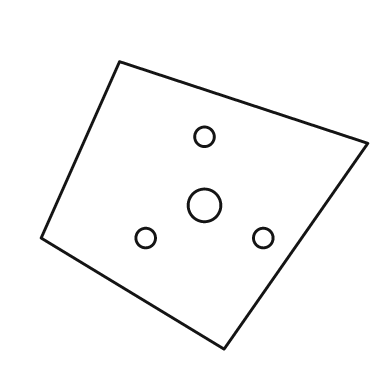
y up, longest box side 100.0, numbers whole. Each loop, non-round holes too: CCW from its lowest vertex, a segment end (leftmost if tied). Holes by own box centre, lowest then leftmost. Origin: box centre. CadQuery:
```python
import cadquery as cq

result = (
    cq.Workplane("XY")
    .moveTo(6.0, -44.0)
    .lineTo(50.0, 19.0)
    .lineTo(-26.0, 44.0)
    .lineTo(-50.0, -10.0)
    .close()
    .moveTo(-18.0, -10.0)
    .circle(3.0)
    .moveTo(18.0, -10.0)
    .circle(3.0)
    .moveTo(0.0, 0.0)
    .circle(5.0)
    .moveTo(0.0, 21.0)
    .circle(3.0)
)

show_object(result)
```